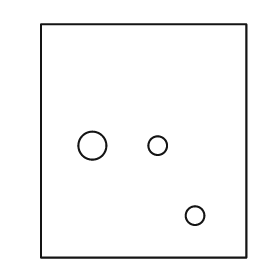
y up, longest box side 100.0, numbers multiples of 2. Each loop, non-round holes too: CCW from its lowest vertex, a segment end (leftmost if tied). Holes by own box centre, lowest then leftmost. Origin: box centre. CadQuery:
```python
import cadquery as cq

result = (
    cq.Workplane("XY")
    .moveTo(-44.0, -50.0)
    .lineTo(44.0, -50.0)
    .lineTo(44.0, 50.0)
    .lineTo(-44.0, 50.0)
    .close()
    .moveTo(22.0, -32.0)
    .circle(4.0)
    .moveTo(-22.0, -2.0)
    .circle(6.0)
    .moveTo(6.0, -2.0)
    .circle(4.0)
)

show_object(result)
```